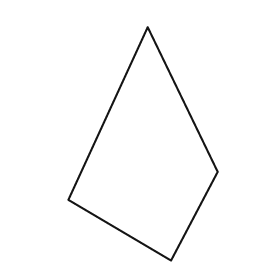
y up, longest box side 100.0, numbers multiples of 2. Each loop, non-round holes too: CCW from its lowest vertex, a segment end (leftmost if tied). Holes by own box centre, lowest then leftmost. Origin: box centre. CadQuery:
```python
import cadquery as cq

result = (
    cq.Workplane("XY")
    .moveTo(12.0, -50.0)
    .lineTo(32.0, -12.0)
    .lineTo(2.0, 50.0)
    .lineTo(-32.0, -24.0)
    .close()
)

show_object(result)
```